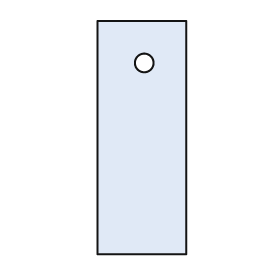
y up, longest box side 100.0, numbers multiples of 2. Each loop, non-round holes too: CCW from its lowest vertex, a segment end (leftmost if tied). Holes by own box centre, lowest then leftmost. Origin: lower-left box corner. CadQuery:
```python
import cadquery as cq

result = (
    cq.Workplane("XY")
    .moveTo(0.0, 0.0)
    .lineTo(38.0, 0.0)
    .lineTo(38.0, 100.0)
    .lineTo(0.0, 100.0)
    .close()
    .moveTo(20.0, 82.0)
    .circle(4.0)
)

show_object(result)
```